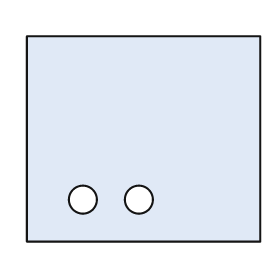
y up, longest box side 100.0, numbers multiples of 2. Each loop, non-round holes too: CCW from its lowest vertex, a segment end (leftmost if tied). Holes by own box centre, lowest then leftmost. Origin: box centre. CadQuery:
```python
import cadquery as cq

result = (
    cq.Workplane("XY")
    .moveTo(-50.0, -44.0)
    .lineTo(50.0, -44.0)
    .lineTo(50.0, 44.0)
    .lineTo(-50.0, 44.0)
    .close()
    .moveTo(-26.0, -26.0)
    .circle(6.0)
    .moveTo(-2.0, -26.0)
    .circle(6.0)
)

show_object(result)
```